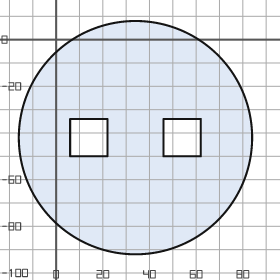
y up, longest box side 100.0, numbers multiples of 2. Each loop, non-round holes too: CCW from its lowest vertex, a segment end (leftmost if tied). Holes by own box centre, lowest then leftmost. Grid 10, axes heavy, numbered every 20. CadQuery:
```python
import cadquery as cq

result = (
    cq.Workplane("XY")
    .moveTo(34.0, -42.0)
    .circle(50.0)
    .moveTo(6.0, -50.0)
    .lineTo(22.0, -50.0)
    .lineTo(22.0, -34.0)
    .lineTo(6.0, -34.0)
    .close()
    .moveTo(46.0, -50.0)
    .lineTo(62.0, -50.0)
    .lineTo(62.0, -34.0)
    .lineTo(46.0, -34.0)
    .close()
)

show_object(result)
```